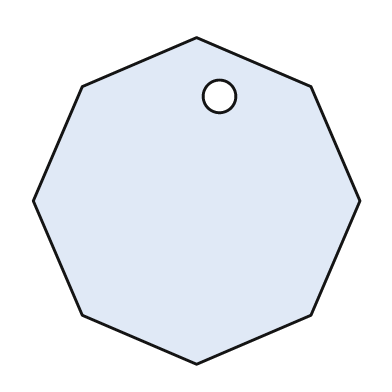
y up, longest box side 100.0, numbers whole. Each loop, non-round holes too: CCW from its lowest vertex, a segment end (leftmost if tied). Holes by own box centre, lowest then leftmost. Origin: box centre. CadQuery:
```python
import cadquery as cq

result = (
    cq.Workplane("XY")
    .moveTo(0.0, -50.0)
    .lineTo(35.0, -35.0)
    .lineTo(50.0, 0.0)
    .lineTo(35.0, 35.0)
    .lineTo(0.0, 50.0)
    .lineTo(-35.0, 35.0)
    .lineTo(-50.0, 0.0)
    .lineTo(-35.0, -35.0)
    .close()
    .moveTo(7.0, 32.0)
    .circle(5.0)
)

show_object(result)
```